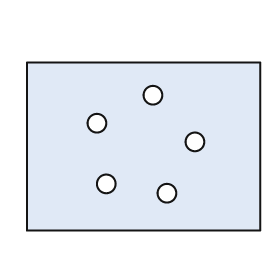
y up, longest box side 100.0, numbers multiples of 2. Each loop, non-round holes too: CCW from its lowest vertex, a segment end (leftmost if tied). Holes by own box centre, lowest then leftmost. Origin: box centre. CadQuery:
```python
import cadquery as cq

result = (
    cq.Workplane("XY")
    .moveTo(-50.0, -36.0)
    .lineTo(50.0, -36.0)
    .lineTo(50.0, 36.0)
    .lineTo(-50.0, 36.0)
    .close()
    .moveTo(10.0, -20.0)
    .circle(4.0)
    .moveTo(-16.0, -16.0)
    .circle(4.0)
    .moveTo(22.0, 2.0)
    .circle(4.0)
    .moveTo(-20.0, 10.0)
    .circle(4.0)
    .moveTo(4.0, 22.0)
    .circle(4.0)
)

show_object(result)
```